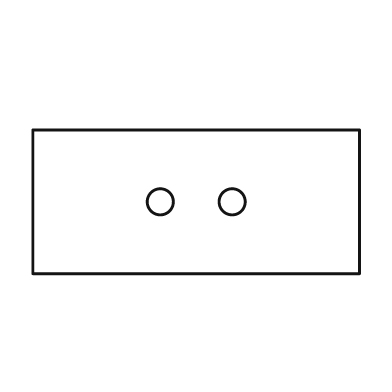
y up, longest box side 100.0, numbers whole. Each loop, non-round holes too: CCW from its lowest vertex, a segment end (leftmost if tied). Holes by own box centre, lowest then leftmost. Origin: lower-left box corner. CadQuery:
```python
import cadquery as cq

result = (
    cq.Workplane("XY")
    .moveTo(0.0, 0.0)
    .lineTo(100.0, 0.0)
    .lineTo(100.0, 44.0)
    .lineTo(0.0, 44.0)
    .close()
    .moveTo(39.0, 22.0)
    .circle(4.0)
    .moveTo(61.0, 22.0)
    .circle(4.0)
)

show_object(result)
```